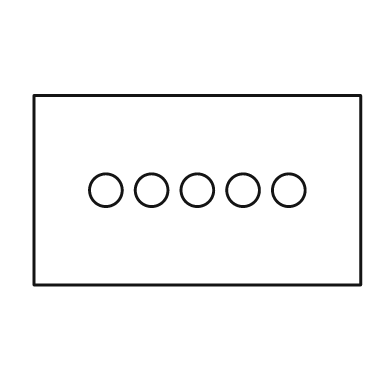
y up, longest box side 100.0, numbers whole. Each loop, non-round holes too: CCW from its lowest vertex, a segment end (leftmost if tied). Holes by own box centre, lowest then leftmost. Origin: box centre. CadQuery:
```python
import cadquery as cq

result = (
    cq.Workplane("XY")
    .moveTo(-50.0, -29.0)
    .lineTo(50.0, -29.0)
    .lineTo(50.0, 29.0)
    .lineTo(-50.0, 29.0)
    .close()
    .moveTo(-28.0, 0.0)
    .circle(5.0)
    .moveTo(-14.0, 0.0)
    .circle(5.0)
    .moveTo(0.0, 0.0)
    .circle(5.0)
    .moveTo(14.0, 0.0)
    .circle(5.0)
    .moveTo(28.0, 0.0)
    .circle(5.0)
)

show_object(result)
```